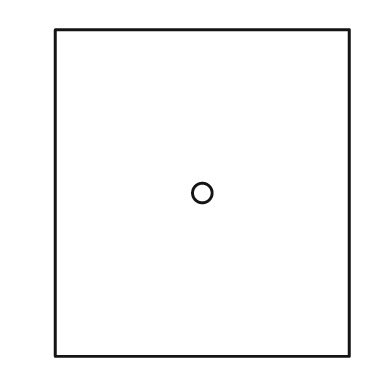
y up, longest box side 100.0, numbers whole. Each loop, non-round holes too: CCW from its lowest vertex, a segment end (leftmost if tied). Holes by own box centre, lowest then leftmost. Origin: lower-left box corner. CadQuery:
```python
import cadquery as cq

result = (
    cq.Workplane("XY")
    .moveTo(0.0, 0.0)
    .lineTo(90.0, 0.0)
    .lineTo(90.0, 100.0)
    .lineTo(0.0, 100.0)
    .close()
    .moveTo(45.0, 50.0)
    .circle(3.0)
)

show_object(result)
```